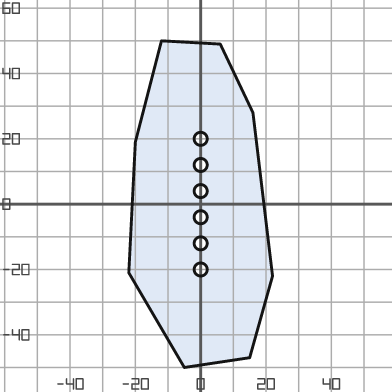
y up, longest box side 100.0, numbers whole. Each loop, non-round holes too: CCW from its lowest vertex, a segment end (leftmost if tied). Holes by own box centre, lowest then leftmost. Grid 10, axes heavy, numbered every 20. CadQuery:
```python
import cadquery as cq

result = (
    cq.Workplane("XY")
    .moveTo(-5.0, -50.0)
    .lineTo(15.0, -47.0)
    .lineTo(22.0, -22.0)
    .lineTo(16.0, 28.0)
    .lineTo(6.0, 49.0)
    .lineTo(-12.0, 50.0)
    .lineTo(-20.0, 19.0)
    .lineTo(-22.0, -21.0)
    .close()
    .moveTo(0.0, -20.0)
    .circle(2.0)
    .moveTo(0.0, -12.0)
    .circle(2.0)
    .moveTo(0.0, -4.0)
    .circle(2.0)
    .moveTo(0.0, 4.0)
    .circle(2.0)
    .moveTo(0.0, 12.0)
    .circle(2.0)
    .moveTo(0.0, 20.0)
    .circle(2.0)
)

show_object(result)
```